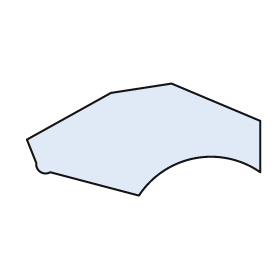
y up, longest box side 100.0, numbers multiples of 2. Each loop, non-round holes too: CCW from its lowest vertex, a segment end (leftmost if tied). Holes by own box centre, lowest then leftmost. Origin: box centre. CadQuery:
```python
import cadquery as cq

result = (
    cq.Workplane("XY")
    .moveTo(-2.0, -24.0)
    .threePointArc((22.0, -8.0), (50.0, -14.0))
    .lineTo(50.0, 8.0)
    .lineTo(12.0, 24.0)
    .lineTo(-14.0, 20.0)
    .lineTo(-50.0, 0.0)
    .lineTo(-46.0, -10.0)
    .threePointArc((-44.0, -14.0), (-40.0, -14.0))
    .close()
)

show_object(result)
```